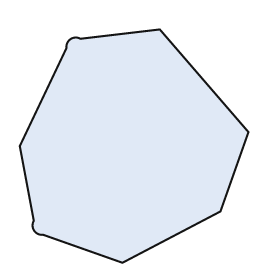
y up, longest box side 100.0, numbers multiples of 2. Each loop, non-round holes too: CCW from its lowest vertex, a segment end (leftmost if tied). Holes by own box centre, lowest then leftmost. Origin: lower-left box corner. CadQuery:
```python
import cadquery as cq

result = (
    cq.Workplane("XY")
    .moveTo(44.0, 0.0)
    .lineTo(86.0, 22.0)
    .lineTo(98.0, 56.0)
    .lineTo(60.0, 100.0)
    .lineTo(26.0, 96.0)
    .threePointArc((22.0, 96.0), (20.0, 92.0))
    .lineTo(0.0, 50.0)
    .lineTo(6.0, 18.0)
    .threePointArc((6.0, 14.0), (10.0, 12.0))
    .close()
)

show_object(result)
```